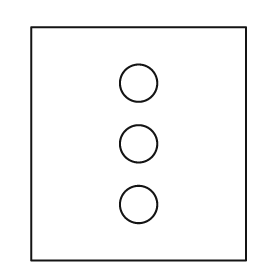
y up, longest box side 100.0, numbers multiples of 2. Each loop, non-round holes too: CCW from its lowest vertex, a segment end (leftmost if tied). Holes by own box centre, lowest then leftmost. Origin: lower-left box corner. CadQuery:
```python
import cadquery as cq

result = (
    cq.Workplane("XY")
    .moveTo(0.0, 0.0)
    .lineTo(92.0, 0.0)
    .lineTo(92.0, 100.0)
    .lineTo(0.0, 100.0)
    .close()
    .moveTo(46.0, 24.0)
    .circle(8.0)
    .moveTo(46.0, 50.0)
    .circle(8.0)
    .moveTo(46.0, 76.0)
    .circle(8.0)
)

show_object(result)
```